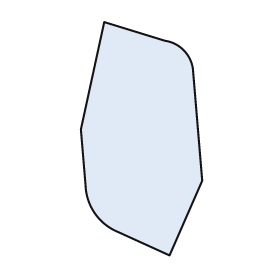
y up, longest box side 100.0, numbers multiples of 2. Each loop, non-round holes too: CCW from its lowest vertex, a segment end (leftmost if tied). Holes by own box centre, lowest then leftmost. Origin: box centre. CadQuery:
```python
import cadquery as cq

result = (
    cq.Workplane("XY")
    .moveTo(12.0, -50.0)
    .lineTo(26.0, -18.0)
    .lineTo(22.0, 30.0)
    .threePointArc((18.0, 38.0), (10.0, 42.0))
    .lineTo(-16.0, 50.0)
    .lineTo(-26.0, 4.0)
    .lineTo(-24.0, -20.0)
    .threePointArc((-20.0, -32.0), (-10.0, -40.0))
    .close()
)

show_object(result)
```